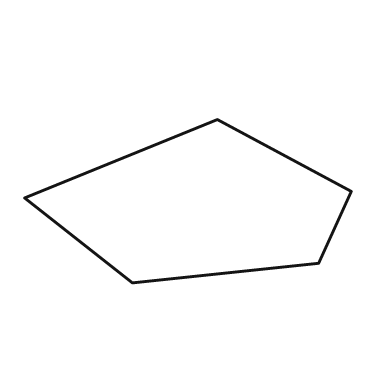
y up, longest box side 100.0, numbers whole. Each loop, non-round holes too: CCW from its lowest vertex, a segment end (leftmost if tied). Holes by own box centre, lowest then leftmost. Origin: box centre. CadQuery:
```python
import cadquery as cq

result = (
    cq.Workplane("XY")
    .moveTo(-17.0, -25.0)
    .lineTo(40.0, -19.0)
    .lineTo(50.0, 3.0)
    .lineTo(9.0, 25.0)
    .lineTo(-50.0, 1.0)
    .close()
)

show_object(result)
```